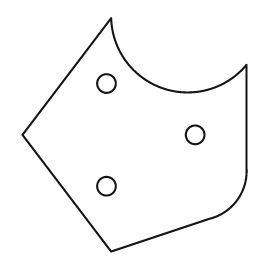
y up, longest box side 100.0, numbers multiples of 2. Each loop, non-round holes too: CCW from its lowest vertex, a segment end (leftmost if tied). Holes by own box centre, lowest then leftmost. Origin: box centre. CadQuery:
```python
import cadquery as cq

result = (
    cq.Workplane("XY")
    .moveTo(-10.0, -50.0)
    .lineTo(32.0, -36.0)
    .threePointArc((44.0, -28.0), (48.0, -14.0))
    .lineTo(48.0, 30.0)
    .threePointArc((12.0, 20.0), (-10.0, 50.0))
    .lineTo(-48.0, 0.0)
    .close()
    .moveTo(-12.0, -22.0)
    .circle(4.0)
    .moveTo(26.0, 0.0)
    .circle(4.0)
    .moveTo(-12.0, 22.0)
    .circle(4.0)
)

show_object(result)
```